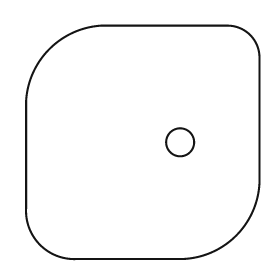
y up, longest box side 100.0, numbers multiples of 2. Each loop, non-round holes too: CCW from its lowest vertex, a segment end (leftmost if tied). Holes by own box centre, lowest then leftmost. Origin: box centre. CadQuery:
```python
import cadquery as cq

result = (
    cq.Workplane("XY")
    .moveTo(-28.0, -50.0)
    .lineTo(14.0, -50.0)
    .threePointArc((40.0, -40.0), (50.0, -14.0))
    .lineTo(50.0, 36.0)
    .threePointArc((46.0, 46.0), (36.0, 50.0))
    .lineTo(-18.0, 50.0)
    .threePointArc((-40.0, 40.0), (-50.0, 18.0))
    .lineTo(-50.0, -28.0)
    .threePointArc((-44.0, -44.0), (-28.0, -50.0))
    .close()
    .moveTo(16.0, 0.0)
    .circle(6.0)
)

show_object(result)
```